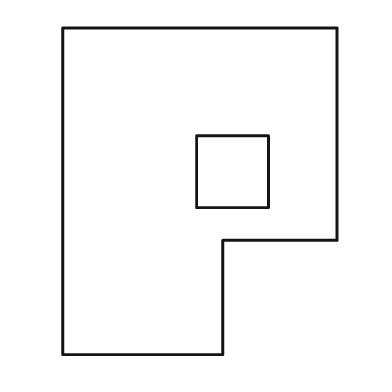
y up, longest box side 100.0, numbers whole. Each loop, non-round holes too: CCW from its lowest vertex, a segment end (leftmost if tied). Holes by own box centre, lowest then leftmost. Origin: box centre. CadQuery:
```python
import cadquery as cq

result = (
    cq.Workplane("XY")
    .moveTo(-42.0, -50.0)
    .lineTo(7.0, -50.0)
    .lineTo(7.0, -15.0)
    .lineTo(42.0, -15.0)
    .lineTo(42.0, 50.0)
    .lineTo(-42.0, 50.0)
    .close()
    .moveTo(-1.0, -5.0)
    .lineTo(21.0, -5.0)
    .lineTo(21.0, 17.0)
    .lineTo(-1.0, 17.0)
    .close()
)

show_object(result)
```